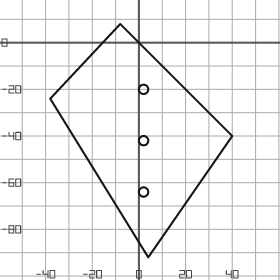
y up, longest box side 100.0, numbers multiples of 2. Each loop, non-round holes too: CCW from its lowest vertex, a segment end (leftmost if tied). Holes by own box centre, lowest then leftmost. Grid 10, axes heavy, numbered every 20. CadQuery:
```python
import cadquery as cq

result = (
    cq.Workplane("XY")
    .moveTo(4.0, -92.0)
    .lineTo(40.0, -40.0)
    .lineTo(-8.0, 8.0)
    .lineTo(-38.0, -24.0)
    .close()
    .moveTo(2.0, -64.0)
    .circle(2.0)
    .moveTo(2.0, -42.0)
    .circle(2.0)
    .moveTo(2.0, -20.0)
    .circle(2.0)
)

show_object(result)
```